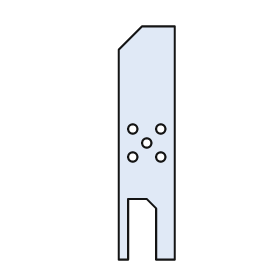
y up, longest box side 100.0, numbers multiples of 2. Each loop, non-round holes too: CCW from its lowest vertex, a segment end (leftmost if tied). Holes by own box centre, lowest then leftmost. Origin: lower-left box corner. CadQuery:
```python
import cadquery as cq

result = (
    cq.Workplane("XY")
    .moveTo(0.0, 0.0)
    .lineTo(4.0, 0.0)
    .lineTo(4.0, 26.0)
    .lineTo(12.0, 26.0)
    .lineTo(16.0, 22.0)
    .lineTo(16.0, 0.0)
    .lineTo(24.0, 0.0)
    .lineTo(24.0, 100.0)
    .lineTo(10.0, 100.0)
    .lineTo(0.0, 90.0)
    .close()
    .moveTo(6.0, 44.0)
    .circle(2.0)
    .moveTo(18.0, 44.0)
    .circle(2.0)
    .moveTo(12.0, 50.0)
    .circle(2.0)
    .moveTo(6.0, 56.0)
    .circle(2.0)
    .moveTo(18.0, 56.0)
    .circle(2.0)
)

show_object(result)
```